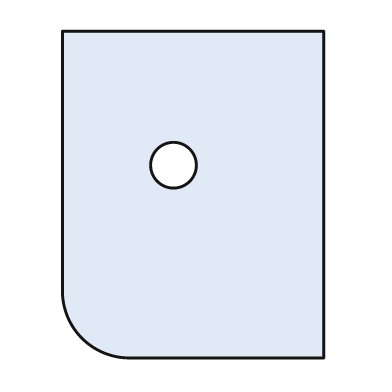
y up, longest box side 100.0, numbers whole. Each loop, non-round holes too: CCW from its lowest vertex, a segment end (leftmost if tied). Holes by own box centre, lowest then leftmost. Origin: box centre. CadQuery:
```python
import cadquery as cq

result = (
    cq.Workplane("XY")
    .moveTo(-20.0, -50.0)
    .lineTo(40.0, -50.0)
    .lineTo(40.0, 50.0)
    .lineTo(-40.0, 50.0)
    .lineTo(-40.0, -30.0)
    .threePointArc((-34.0, -44.0), (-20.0, -50.0))
    .close()
    .moveTo(-6.0, 9.0)
    .circle(7.0)
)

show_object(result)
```